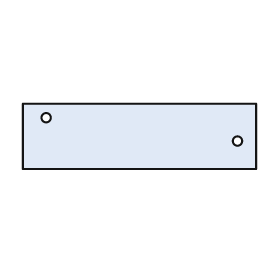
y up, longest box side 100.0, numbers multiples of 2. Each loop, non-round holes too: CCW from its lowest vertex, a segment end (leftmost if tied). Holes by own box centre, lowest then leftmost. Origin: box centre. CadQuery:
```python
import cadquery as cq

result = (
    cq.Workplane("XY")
    .moveTo(-50.0, -14.0)
    .lineTo(50.0, -14.0)
    .lineTo(50.0, 14.0)
    .lineTo(-50.0, 14.0)
    .close()
    .moveTo(42.0, -2.0)
    .circle(2.0)
    .moveTo(-40.0, 8.0)
    .circle(2.0)
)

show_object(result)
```